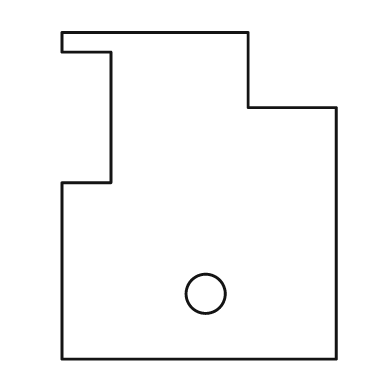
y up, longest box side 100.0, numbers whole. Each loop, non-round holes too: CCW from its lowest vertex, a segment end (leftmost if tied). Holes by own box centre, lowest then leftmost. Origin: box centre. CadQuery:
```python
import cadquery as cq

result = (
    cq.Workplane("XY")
    .moveTo(-42.0, -50.0)
    .lineTo(42.0, -50.0)
    .lineTo(42.0, 27.0)
    .lineTo(15.0, 27.0)
    .lineTo(15.0, 50.0)
    .lineTo(-42.0, 50.0)
    .lineTo(-42.0, 44.0)
    .lineTo(-27.0, 44.0)
    .lineTo(-27.0, 4.0)
    .lineTo(-42.0, 4.0)
    .close()
    .moveTo(2.0, -30.0)
    .circle(6.0)
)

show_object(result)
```